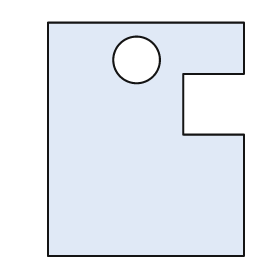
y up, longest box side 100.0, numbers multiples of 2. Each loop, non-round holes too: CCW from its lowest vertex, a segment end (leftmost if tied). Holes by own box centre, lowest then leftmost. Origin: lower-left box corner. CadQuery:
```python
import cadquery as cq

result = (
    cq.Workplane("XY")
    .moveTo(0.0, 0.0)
    .lineTo(84.0, 0.0)
    .lineTo(84.0, 52.0)
    .lineTo(58.0, 52.0)
    .lineTo(58.0, 78.0)
    .lineTo(84.0, 78.0)
    .lineTo(84.0, 100.0)
    .lineTo(0.0, 100.0)
    .close()
    .moveTo(38.0, 84.0)
    .circle(10.0)
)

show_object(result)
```